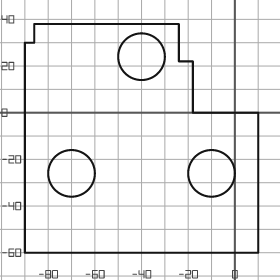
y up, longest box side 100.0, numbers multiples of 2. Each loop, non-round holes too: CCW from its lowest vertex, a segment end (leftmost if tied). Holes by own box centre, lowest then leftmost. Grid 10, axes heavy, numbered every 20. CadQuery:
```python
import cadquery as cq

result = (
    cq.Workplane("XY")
    .moveTo(-90.0, -60.0)
    .lineTo(10.0, -60.0)
    .lineTo(10.0, 0.0)
    .lineTo(-18.0, 0.0)
    .lineTo(-18.0, 22.0)
    .lineTo(-24.0, 22.0)
    .lineTo(-24.0, 38.0)
    .lineTo(-86.0, 38.0)
    .lineTo(-86.0, 30.0)
    .lineTo(-90.0, 30.0)
    .close()
    .moveTo(-70.0, -26.0)
    .circle(10.0)
    .moveTo(-10.0, -26.0)
    .circle(10.0)
    .moveTo(-40.0, 24.0)
    .circle(10.0)
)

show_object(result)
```